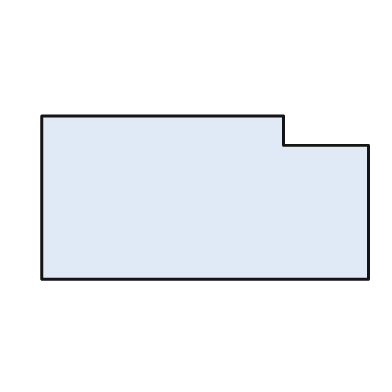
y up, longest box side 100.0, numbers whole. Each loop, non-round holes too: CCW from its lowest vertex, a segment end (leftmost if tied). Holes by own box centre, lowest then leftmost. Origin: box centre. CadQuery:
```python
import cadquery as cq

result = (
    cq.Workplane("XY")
    .moveTo(-50.0, -25.0)
    .lineTo(50.0, -25.0)
    .lineTo(50.0, 16.0)
    .lineTo(24.0, 16.0)
    .lineTo(24.0, 25.0)
    .lineTo(-50.0, 25.0)
    .close()
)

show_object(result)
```